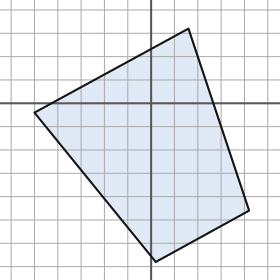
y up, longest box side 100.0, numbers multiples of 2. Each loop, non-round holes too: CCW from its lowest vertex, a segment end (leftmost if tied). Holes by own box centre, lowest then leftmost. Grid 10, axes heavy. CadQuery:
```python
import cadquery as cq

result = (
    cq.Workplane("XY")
    .moveTo(2.0, -68.0)
    .lineTo(42.0, -46.0)
    .lineTo(16.0, 32.0)
    .lineTo(-50.0, -4.0)
    .close()
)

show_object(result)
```